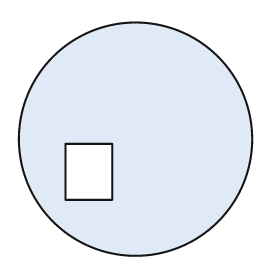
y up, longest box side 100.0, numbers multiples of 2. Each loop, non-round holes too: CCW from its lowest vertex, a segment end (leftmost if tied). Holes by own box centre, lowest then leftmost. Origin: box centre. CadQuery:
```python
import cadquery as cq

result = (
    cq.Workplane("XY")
    .moveTo(0.0, 0.0)
    .circle(50.0)
    .moveTo(-30.0, -26.0)
    .lineTo(-10.0, -26.0)
    .lineTo(-10.0, -2.0)
    .lineTo(-30.0, -2.0)
    .close()
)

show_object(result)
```